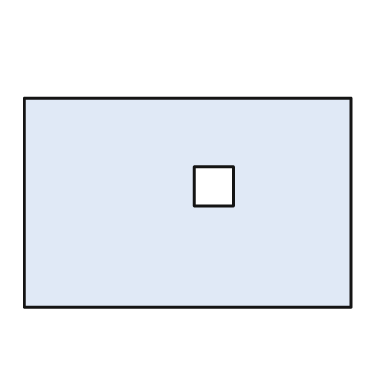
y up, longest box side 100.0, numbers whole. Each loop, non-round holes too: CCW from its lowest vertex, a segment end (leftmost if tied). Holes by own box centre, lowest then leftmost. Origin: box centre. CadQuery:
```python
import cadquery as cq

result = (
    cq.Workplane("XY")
    .moveTo(-50.0, -32.0)
    .lineTo(50.0, -32.0)
    .lineTo(50.0, 32.0)
    .lineTo(-50.0, 32.0)
    .close()
    .moveTo(2.0, -1.0)
    .lineTo(14.0, -1.0)
    .lineTo(14.0, 11.0)
    .lineTo(2.0, 11.0)
    .close()
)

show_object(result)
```